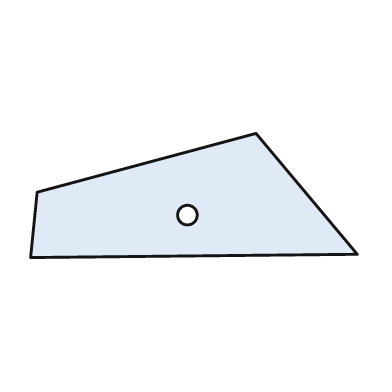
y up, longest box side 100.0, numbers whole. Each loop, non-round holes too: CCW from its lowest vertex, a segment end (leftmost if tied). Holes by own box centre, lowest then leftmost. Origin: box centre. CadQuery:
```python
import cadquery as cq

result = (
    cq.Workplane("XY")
    .moveTo(-50.0, -19.0)
    .lineTo(50.0, -18.0)
    .lineTo(19.0, 19.0)
    .lineTo(-48.0, 1.0)
    .close()
    .moveTo(-2.0, -6.0)
    .circle(3.0)
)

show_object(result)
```